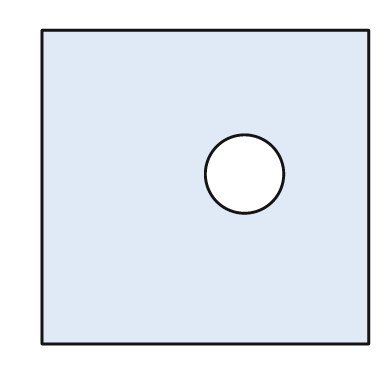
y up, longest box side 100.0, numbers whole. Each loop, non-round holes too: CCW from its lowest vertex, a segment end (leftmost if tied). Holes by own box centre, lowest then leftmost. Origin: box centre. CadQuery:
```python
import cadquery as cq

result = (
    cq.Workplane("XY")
    .moveTo(-50.0, -48.0)
    .lineTo(50.0, -48.0)
    .lineTo(50.0, 48.0)
    .lineTo(-50.0, 48.0)
    .close()
    .moveTo(12.0, 4.0)
    .circle(12.0)
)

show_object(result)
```